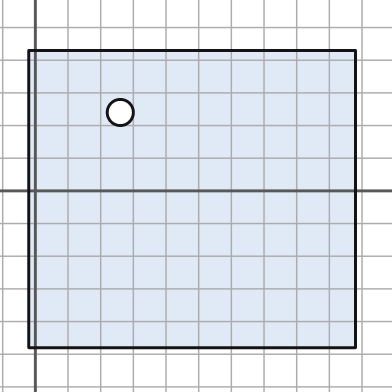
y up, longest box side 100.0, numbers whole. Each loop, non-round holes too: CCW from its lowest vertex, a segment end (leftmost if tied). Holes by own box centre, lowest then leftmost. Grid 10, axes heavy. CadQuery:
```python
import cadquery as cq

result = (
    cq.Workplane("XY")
    .moveTo(-2.0, -48.0)
    .lineTo(98.0, -48.0)
    .lineTo(98.0, 43.0)
    .lineTo(-2.0, 43.0)
    .close()
    .moveTo(26.0, 24.0)
    .circle(4.0)
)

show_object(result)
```